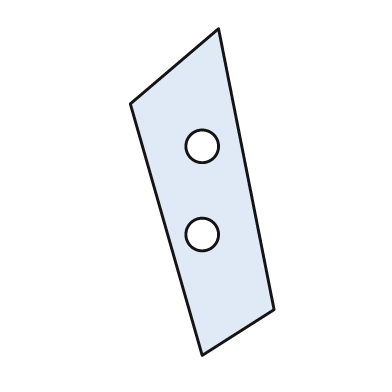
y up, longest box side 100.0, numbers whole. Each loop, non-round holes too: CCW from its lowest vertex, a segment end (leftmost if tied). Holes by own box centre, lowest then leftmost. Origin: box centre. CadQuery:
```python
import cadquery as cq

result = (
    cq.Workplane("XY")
    .moveTo(0.0, -50.0)
    .lineTo(22.0, -36.0)
    .lineTo(5.0, 50.0)
    .lineTo(-22.0, 27.0)
    .close()
    .moveTo(0.0, -13.0)
    .circle(5.0)
    .moveTo(0.0, 14.0)
    .circle(5.0)
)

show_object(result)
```